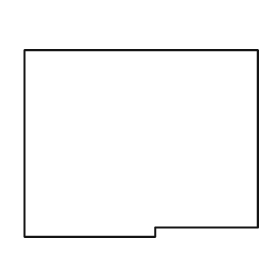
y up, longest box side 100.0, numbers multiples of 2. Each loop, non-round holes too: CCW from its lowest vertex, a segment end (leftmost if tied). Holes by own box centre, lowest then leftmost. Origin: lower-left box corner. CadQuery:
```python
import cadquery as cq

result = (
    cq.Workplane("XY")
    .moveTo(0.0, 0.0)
    .lineTo(56.0, 0.0)
    .lineTo(56.0, 4.0)
    .lineTo(100.0, 4.0)
    .lineTo(100.0, 80.0)
    .lineTo(0.0, 80.0)
    .close()
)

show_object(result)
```